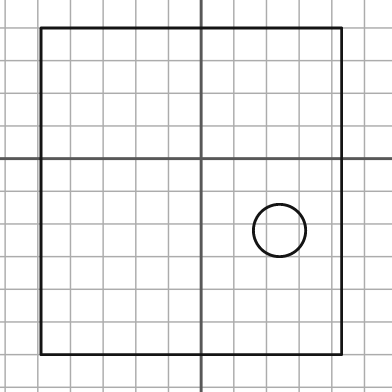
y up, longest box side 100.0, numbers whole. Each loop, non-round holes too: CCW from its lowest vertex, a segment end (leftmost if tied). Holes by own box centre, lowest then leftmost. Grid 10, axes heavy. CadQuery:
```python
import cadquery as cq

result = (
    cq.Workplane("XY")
    .moveTo(-49.0, -60.0)
    .lineTo(43.0, -60.0)
    .lineTo(43.0, 40.0)
    .lineTo(-49.0, 40.0)
    .close()
    .moveTo(24.0, -22.0)
    .circle(8.0)
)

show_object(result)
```